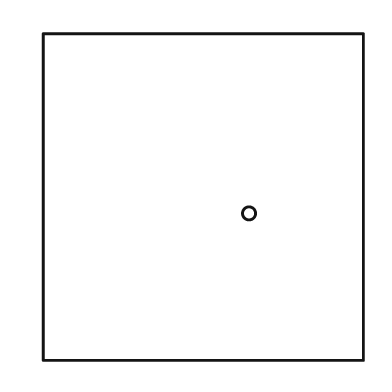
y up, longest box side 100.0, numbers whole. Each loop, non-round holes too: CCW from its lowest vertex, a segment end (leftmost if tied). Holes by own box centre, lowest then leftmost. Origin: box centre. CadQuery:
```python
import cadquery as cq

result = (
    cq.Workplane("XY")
    .moveTo(-49.0, -50.0)
    .lineTo(49.0, -50.0)
    .lineTo(49.0, 50.0)
    .lineTo(-49.0, 50.0)
    .close()
    .moveTo(14.0, -5.0)
    .circle(2.0)
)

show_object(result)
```